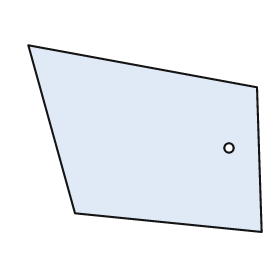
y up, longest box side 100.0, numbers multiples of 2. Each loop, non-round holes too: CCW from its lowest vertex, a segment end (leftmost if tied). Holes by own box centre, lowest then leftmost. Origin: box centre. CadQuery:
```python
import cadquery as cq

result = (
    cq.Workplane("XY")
    .moveTo(50.0, -40.0)
    .lineTo(48.0, 22.0)
    .lineTo(-50.0, 40.0)
    .lineTo(-30.0, -32.0)
    .close()
    .moveTo(36.0, -4.0)
    .circle(2.0)
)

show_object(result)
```